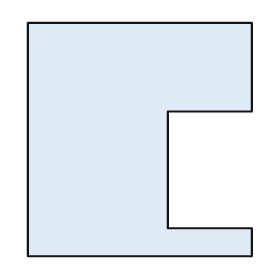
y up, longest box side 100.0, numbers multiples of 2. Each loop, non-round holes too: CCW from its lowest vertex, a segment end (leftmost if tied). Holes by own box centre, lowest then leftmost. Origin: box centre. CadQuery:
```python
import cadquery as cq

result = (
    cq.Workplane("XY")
    .moveTo(-48.0, -50.0)
    .lineTo(48.0, -50.0)
    .lineTo(48.0, -38.0)
    .lineTo(12.0, -38.0)
    .lineTo(12.0, 12.0)
    .lineTo(48.0, 12.0)
    .lineTo(48.0, 50.0)
    .lineTo(-48.0, 50.0)
    .close()
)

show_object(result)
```